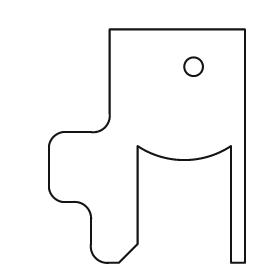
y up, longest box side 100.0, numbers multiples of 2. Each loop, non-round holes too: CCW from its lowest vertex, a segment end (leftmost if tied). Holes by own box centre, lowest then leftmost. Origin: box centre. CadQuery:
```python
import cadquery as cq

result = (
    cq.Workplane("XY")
    .moveTo(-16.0, -50.0)
    .lineTo(-12.0, -50.0)
    .lineTo(-4.0, -42.0)
    .lineTo(-4.0, 0.0)
    .threePointArc((16.0, -6.0), (36.0, 0.0))
    .lineTo(36.0, -50.0)
    .lineTo(42.0, -50.0)
    .lineTo(42.0, 50.0)
    .lineTo(-16.0, 50.0)
    .lineTo(-16.0, 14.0)
    .threePointArc((-18.0, 8.0), (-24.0, 6.0))
    .lineTo(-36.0, 6.0)
    .threePointArc((-40.0, 4.0), (-42.0, 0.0))
    .lineTo(-42.0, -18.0)
    .threePointArc((-40.0, -22.0), (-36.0, -24.0))
    .lineTo(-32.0, -24.0)
    .threePointArc((-26.0, -26.0), (-24.0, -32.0))
    .lineTo(-24.0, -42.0)
    .threePointArc((-22.0, -48.0), (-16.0, -50.0))
    .close()
    .moveTo(20.0, 34.0)
    .circle(4.0)
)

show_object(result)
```